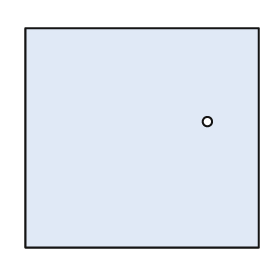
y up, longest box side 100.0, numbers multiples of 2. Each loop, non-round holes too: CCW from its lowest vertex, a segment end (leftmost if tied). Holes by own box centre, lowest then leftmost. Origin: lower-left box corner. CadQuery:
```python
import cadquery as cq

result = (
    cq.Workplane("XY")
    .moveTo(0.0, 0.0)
    .lineTo(100.0, 0.0)
    .lineTo(100.0, 94.0)
    .lineTo(0.0, 94.0)
    .close()
    .moveTo(78.0, 54.0)
    .circle(2.0)
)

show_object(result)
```